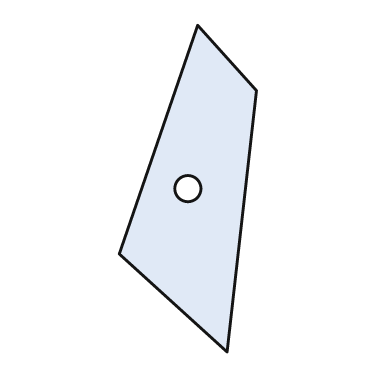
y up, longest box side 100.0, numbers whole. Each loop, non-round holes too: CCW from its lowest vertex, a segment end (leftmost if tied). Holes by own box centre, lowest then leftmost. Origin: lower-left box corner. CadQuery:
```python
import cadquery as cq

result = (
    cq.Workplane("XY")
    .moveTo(33.0, 0.0)
    .lineTo(42.0, 80.0)
    .lineTo(24.0, 100.0)
    .lineTo(0.0, 30.0)
    .close()
    .moveTo(21.0, 50.0)
    .circle(4.0)
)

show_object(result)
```